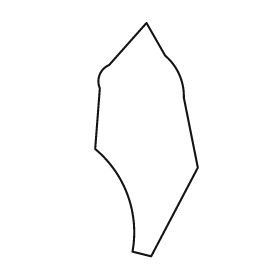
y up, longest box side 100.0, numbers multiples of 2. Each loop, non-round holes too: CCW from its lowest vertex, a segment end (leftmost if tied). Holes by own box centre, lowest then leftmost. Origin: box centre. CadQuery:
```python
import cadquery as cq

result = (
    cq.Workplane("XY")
    .moveTo(2.0, -50.0)
    .lineTo(22.0, -12.0)
    .lineTo(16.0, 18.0)
    .threePointArc((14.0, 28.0), (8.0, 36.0))
    .lineTo(0.0, 50.0)
    .lineTo(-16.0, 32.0)
    .threePointArc((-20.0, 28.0), (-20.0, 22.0))
    .lineTo(-22.0, -4.0)
    .threePointArc((-8.0, -24.0), (-6.0, -48.0))
    .close()
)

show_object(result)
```